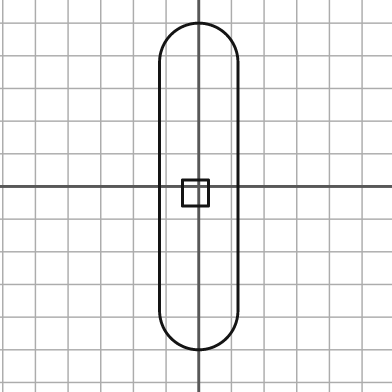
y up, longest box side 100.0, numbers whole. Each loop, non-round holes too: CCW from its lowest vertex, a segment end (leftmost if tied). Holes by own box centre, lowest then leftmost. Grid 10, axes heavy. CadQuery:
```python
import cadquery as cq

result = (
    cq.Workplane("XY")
    .moveTo(-12.0, -38.0)
    .threePointArc((0.0, -50.0), (12.0, -38.0))
    .lineTo(12.0, 38.0)
    .threePointArc((0.0, 50.0), (-12.0, 38.0))
    .close()
    .moveTo(-5.0, -6.0)
    .lineTo(3.0, -6.0)
    .lineTo(3.0, 2.0)
    .lineTo(-5.0, 2.0)
    .close()
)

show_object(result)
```